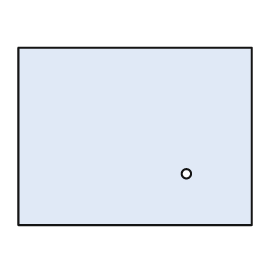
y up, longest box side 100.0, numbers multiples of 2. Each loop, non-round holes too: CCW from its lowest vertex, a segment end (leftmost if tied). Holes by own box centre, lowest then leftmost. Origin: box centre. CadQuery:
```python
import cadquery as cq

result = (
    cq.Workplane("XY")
    .moveTo(-50.0, -38.0)
    .lineTo(50.0, -38.0)
    .lineTo(50.0, 38.0)
    .lineTo(-50.0, 38.0)
    .close()
    .moveTo(22.0, -16.0)
    .circle(2.0)
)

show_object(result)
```